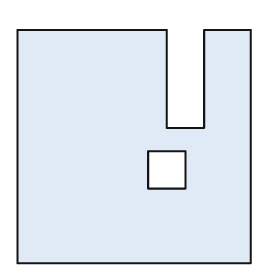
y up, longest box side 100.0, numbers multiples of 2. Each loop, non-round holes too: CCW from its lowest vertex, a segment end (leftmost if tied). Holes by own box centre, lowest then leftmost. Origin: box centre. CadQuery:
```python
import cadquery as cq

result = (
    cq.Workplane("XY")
    .moveTo(-50.0, -50.0)
    .lineTo(50.0, -50.0)
    .lineTo(50.0, 50.0)
    .lineTo(30.0, 50.0)
    .lineTo(30.0, 8.0)
    .lineTo(14.0, 8.0)
    .lineTo(14.0, 50.0)
    .lineTo(-50.0, 50.0)
    .close()
    .moveTo(6.0, -18.0)
    .lineTo(22.0, -18.0)
    .lineTo(22.0, -2.0)
    .lineTo(6.0, -2.0)
    .close()
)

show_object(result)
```